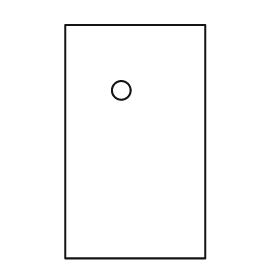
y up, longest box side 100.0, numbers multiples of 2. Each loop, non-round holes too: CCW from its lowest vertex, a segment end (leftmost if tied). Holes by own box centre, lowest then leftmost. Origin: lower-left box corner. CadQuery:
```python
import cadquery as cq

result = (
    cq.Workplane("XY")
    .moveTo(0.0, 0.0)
    .lineTo(60.0, 0.0)
    .lineTo(60.0, 100.0)
    .lineTo(0.0, 100.0)
    .close()
    .moveTo(24.0, 72.0)
    .circle(4.0)
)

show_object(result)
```